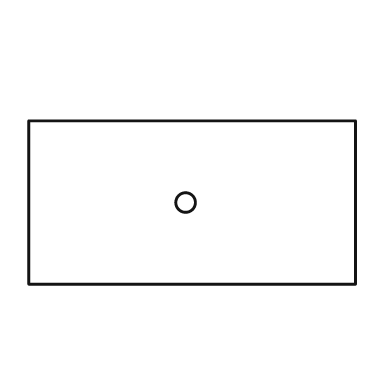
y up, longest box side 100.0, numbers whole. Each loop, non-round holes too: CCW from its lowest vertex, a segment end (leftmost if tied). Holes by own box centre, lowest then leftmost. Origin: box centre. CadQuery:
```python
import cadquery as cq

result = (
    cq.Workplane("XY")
    .moveTo(-50.0, -25.0)
    .lineTo(50.0, -25.0)
    .lineTo(50.0, 25.0)
    .lineTo(-50.0, 25.0)
    .close()
    .moveTo(-2.0, 0.0)
    .circle(3.0)
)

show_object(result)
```